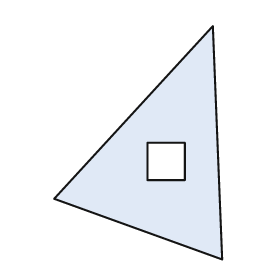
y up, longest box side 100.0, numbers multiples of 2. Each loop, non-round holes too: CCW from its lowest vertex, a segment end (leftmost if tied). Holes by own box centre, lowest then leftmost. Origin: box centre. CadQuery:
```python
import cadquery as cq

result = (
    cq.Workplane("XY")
    .moveTo(36.0, -50.0)
    .lineTo(32.0, 50.0)
    .lineTo(-36.0, -24.0)
    .close()
    .moveTo(4.0, -16.0)
    .lineTo(20.0, -16.0)
    .lineTo(20.0, 0.0)
    .lineTo(4.0, 0.0)
    .close()
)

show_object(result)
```